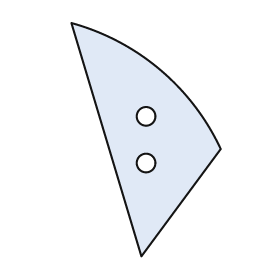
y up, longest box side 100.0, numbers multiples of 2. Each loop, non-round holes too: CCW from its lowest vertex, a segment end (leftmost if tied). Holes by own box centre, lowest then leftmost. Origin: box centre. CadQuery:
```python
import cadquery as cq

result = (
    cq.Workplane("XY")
    .moveTo(-2.0, -50.0)
    .lineTo(32.0, -4.0)
    .threePointArc((6.0, 30.0), (-32.0, 50.0))
    .close()
    .moveTo(0.0, -10.0)
    .circle(4.0)
    .moveTo(0.0, 10.0)
    .circle(4.0)
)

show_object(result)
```